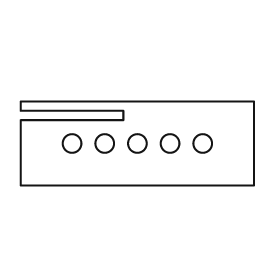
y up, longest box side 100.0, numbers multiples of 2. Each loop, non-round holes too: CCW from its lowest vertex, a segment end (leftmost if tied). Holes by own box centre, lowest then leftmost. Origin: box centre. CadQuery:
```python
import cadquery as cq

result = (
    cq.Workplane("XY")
    .moveTo(-50.0, -18.0)
    .lineTo(50.0, -18.0)
    .lineTo(50.0, 18.0)
    .lineTo(-50.0, 18.0)
    .lineTo(-50.0, 14.0)
    .lineTo(-6.0, 14.0)
    .lineTo(-6.0, 10.0)
    .lineTo(-50.0, 10.0)
    .close()
    .moveTo(-28.0, 0.0)
    .circle(4.0)
    .moveTo(-14.0, 0.0)
    .circle(4.0)
    .moveTo(0.0, 0.0)
    .circle(4.0)
    .moveTo(14.0, 0.0)
    .circle(4.0)
    .moveTo(28.0, 0.0)
    .circle(4.0)
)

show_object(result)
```